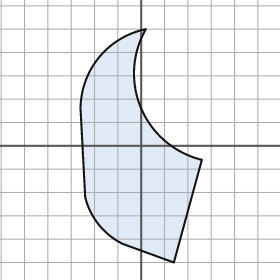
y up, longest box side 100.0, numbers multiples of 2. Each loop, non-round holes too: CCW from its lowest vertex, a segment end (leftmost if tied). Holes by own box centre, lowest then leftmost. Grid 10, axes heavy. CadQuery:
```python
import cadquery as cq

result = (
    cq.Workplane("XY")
    .moveTo(14.0, -50.0)
    .lineTo(26.0, -6.0)
    .threePointArc((0.0, 16.0), (2.0, 50.0))
    .threePointArc((-18.0, 38.0), (-26.0, 16.0))
    .lineTo(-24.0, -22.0)
    .threePointArc((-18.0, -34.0), (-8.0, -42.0))
    .close()
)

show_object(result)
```